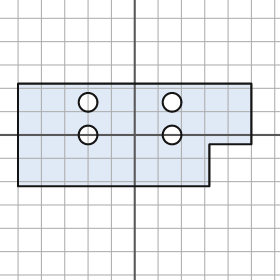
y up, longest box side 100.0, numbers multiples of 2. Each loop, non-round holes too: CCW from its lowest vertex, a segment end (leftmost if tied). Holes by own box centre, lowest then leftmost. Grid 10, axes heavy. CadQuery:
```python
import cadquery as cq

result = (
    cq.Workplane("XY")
    .moveTo(-50.0, -22.0)
    .lineTo(32.0, -22.0)
    .lineTo(32.0, -4.0)
    .lineTo(50.0, -4.0)
    .lineTo(50.0, 22.0)
    .lineTo(-50.0, 22.0)
    .close()
    .moveTo(-20.0, 0.0)
    .circle(4.0)
    .moveTo(16.0, 0.0)
    .circle(4.0)
    .moveTo(-20.0, 14.0)
    .circle(4.0)
    .moveTo(16.0, 14.0)
    .circle(4.0)
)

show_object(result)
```